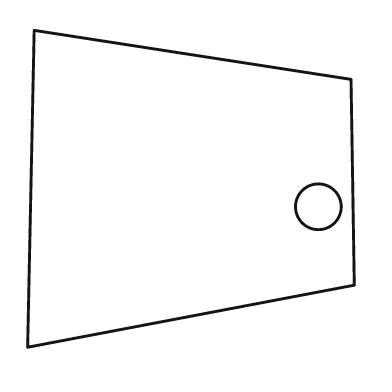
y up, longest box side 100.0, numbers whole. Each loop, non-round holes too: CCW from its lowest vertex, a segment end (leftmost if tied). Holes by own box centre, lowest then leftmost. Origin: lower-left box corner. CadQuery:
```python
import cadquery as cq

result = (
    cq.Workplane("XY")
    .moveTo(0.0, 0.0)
    .lineTo(100.0, 19.0)
    .lineTo(99.0, 82.0)
    .lineTo(2.0, 97.0)
    .close()
    .moveTo(89.0, 43.0)
    .circle(7.0)
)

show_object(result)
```